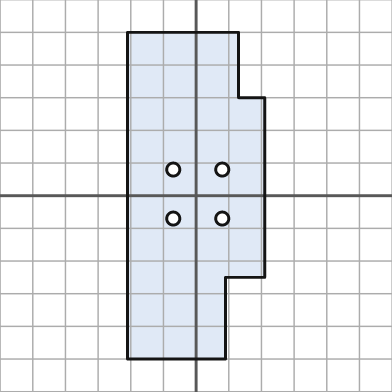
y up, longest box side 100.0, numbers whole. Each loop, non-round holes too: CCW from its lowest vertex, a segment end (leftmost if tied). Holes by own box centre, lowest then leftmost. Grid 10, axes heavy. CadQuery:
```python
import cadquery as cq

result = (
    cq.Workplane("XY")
    .moveTo(-21.0, -50.0)
    .lineTo(9.0, -50.0)
    .lineTo(9.0, -25.0)
    .lineTo(21.0, -25.0)
    .lineTo(21.0, 30.0)
    .lineTo(13.0, 30.0)
    .lineTo(13.0, 50.0)
    .lineTo(-21.0, 50.0)
    .close()
    .moveTo(-7.0, -7.0)
    .circle(2.0)
    .moveTo(8.0, -7.0)
    .circle(2.0)
    .moveTo(-7.0, 8.0)
    .circle(2.0)
    .moveTo(8.0, 8.0)
    .circle(2.0)
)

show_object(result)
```